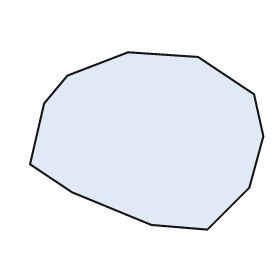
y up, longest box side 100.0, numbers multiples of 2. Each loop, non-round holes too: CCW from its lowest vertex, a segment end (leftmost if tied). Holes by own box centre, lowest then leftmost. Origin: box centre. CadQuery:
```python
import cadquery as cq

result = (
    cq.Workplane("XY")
    .moveTo(26.0, -38.0)
    .lineTo(44.0, -20.0)
    .lineTo(50.0, 2.0)
    .lineTo(46.0, 20.0)
    .lineTo(22.0, 36.0)
    .lineTo(-8.0, 38.0)
    .lineTo(-34.0, 28.0)
    .lineTo(-44.0, 16.0)
    .lineTo(-50.0, -10.0)
    .lineTo(-32.0, -22.0)
    .lineTo(2.0, -36.0)
    .close()
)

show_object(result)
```